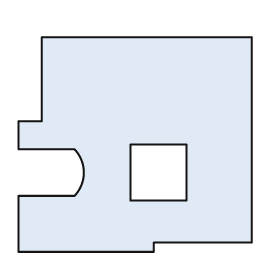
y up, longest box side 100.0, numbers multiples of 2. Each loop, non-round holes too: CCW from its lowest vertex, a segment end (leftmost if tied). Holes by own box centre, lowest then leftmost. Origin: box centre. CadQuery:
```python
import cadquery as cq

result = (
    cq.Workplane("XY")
    .moveTo(-50.0, -46.0)
    .lineTo(8.0, -46.0)
    .lineTo(8.0, -42.0)
    .lineTo(50.0, -42.0)
    .lineTo(50.0, 46.0)
    .lineTo(-40.0, 46.0)
    .lineTo(-40.0, 10.0)
    .lineTo(-50.0, 10.0)
    .lineTo(-50.0, -2.0)
    .lineTo(-26.0, -2.0)
    .threePointArc((-22.0, -12.0), (-26.0, -22.0))
    .lineTo(-50.0, -22.0)
    .close()
    .moveTo(-2.0, -24.0)
    .lineTo(22.0, -24.0)
    .lineTo(22.0, 0.0)
    .lineTo(-2.0, 0.0)
    .close()
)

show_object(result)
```